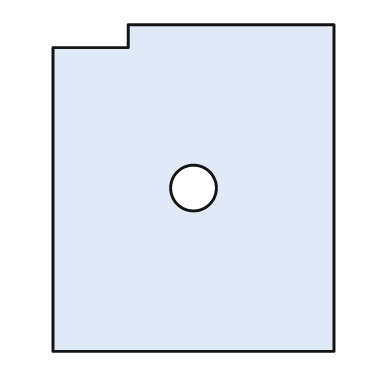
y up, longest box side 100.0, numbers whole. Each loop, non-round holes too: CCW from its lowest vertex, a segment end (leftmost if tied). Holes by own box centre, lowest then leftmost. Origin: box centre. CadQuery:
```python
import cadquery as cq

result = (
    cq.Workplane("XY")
    .moveTo(-43.0, -50.0)
    .lineTo(43.0, -50.0)
    .lineTo(43.0, 50.0)
    .lineTo(-20.0, 50.0)
    .lineTo(-20.0, 43.0)
    .lineTo(-43.0, 43.0)
    .close()
    .moveTo(0.0, 0.0)
    .circle(7.0)
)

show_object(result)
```